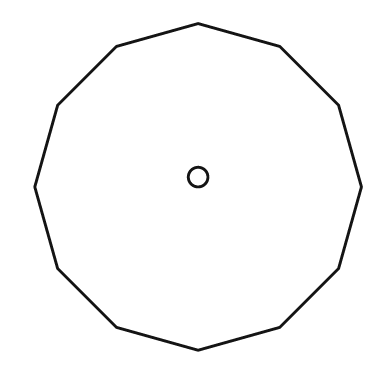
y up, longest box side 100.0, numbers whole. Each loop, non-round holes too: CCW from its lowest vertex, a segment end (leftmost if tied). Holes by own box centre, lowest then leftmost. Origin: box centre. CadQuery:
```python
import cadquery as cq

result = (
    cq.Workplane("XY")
    .moveTo(0.0, -50.0)
    .lineTo(25.0, -43.0)
    .lineTo(43.0, -25.0)
    .lineTo(50.0, 0.0)
    .lineTo(43.0, 25.0)
    .lineTo(25.0, 43.0)
    .lineTo(0.0, 50.0)
    .lineTo(-25.0, 43.0)
    .lineTo(-43.0, 25.0)
    .lineTo(-50.0, 0.0)
    .lineTo(-43.0, -25.0)
    .lineTo(-25.0, -43.0)
    .close()
    .moveTo(0.0, 3.0)
    .circle(3.0)
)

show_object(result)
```